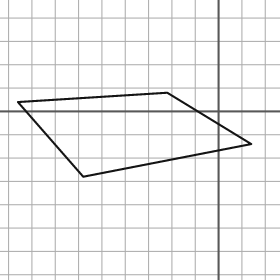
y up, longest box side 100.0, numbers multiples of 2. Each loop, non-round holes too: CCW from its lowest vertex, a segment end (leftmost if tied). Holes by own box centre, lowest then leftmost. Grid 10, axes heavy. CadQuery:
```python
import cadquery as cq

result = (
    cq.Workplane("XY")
    .moveTo(-58.0, -28.0)
    .lineTo(14.0, -14.0)
    .lineTo(-22.0, 8.0)
    .lineTo(-86.0, 4.0)
    .close()
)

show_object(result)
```